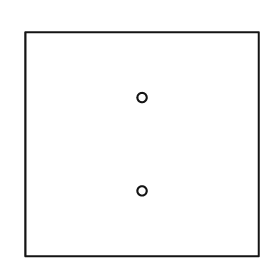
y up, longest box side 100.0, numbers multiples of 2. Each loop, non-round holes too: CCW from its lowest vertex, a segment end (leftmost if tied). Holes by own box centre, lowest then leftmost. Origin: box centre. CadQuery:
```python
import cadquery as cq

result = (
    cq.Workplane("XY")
    .moveTo(-50.0, -48.0)
    .lineTo(50.0, -48.0)
    .lineTo(50.0, 48.0)
    .lineTo(-50.0, 48.0)
    .close()
    .moveTo(0.0, -20.0)
    .circle(2.0)
    .moveTo(0.0, 20.0)
    .circle(2.0)
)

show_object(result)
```